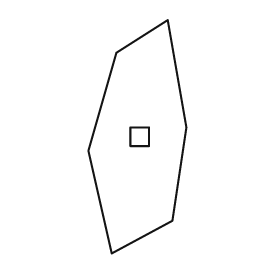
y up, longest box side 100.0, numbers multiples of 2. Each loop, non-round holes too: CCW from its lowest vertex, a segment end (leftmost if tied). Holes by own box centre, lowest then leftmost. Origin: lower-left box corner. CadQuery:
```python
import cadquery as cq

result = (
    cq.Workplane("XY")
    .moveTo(10.0, 0.0)
    .lineTo(36.0, 14.0)
    .lineTo(42.0, 54.0)
    .lineTo(34.0, 100.0)
    .lineTo(12.0, 86.0)
    .lineTo(0.0, 44.0)
    .close()
    .moveTo(18.0, 46.0)
    .lineTo(26.0, 46.0)
    .lineTo(26.0, 54.0)
    .lineTo(18.0, 54.0)
    .close()
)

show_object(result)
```